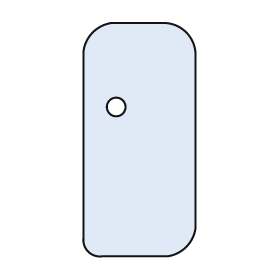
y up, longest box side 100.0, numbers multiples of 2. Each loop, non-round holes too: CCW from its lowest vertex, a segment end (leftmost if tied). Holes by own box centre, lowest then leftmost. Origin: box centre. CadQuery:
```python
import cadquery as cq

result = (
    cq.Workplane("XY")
    .moveTo(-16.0, -50.0)
    .lineTo(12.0, -50.0)
    .threePointArc((20.0, -46.0), (24.0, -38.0))
    .lineTo(24.0, 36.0)
    .threePointArc((20.0, 46.0), (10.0, 50.0))
    .lineTo(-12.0, 50.0)
    .threePointArc((-20.0, 46.0), (-24.0, 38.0))
    .lineTo(-24.0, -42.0)
    .threePointArc((-22.0, -48.0), (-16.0, -50.0))
    .close()
    .moveTo(-10.0, 14.0)
    .circle(4.0)
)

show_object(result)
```